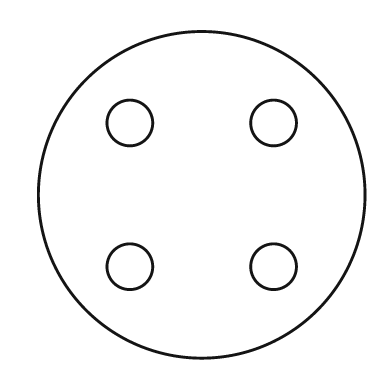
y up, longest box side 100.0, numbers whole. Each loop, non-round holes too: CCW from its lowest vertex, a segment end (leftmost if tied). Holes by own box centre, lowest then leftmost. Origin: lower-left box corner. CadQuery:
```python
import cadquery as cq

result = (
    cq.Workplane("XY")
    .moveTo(50.0, 50.0)
    .circle(50.0)
    .moveTo(28.0, 28.0)
    .circle(7.0)
    .moveTo(72.0, 28.0)
    .circle(7.0)
    .moveTo(28.0, 72.0)
    .circle(7.0)
    .moveTo(72.0, 72.0)
    .circle(7.0)
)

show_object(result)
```